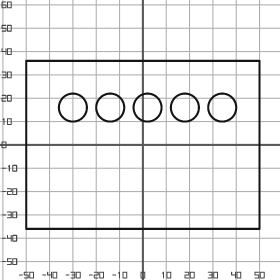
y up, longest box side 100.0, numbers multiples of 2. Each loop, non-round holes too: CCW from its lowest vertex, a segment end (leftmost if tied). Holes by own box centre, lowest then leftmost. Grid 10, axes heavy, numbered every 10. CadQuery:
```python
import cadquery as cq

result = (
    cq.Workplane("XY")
    .moveTo(-50.0, -36.0)
    .lineTo(50.0, -36.0)
    .lineTo(50.0, 36.0)
    .lineTo(-50.0, 36.0)
    .close()
    .moveTo(-30.0, 16.0)
    .circle(6.0)
    .moveTo(-14.0, 16.0)
    .circle(6.0)
    .moveTo(2.0, 16.0)
    .circle(6.0)
    .moveTo(18.0, 16.0)
    .circle(6.0)
    .moveTo(34.0, 16.0)
    .circle(6.0)
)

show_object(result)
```